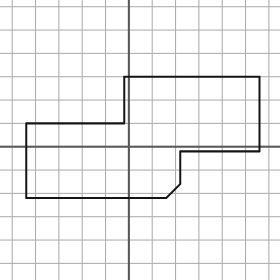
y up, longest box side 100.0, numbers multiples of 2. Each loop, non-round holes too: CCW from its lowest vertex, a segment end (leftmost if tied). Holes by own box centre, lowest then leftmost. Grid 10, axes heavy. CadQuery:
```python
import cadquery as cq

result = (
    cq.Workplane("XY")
    .moveTo(-44.0, -22.0)
    .lineTo(16.0, -22.0)
    .lineTo(22.0, -16.0)
    .lineTo(22.0, -2.0)
    .lineTo(56.0, -2.0)
    .lineTo(56.0, 30.0)
    .lineTo(-2.0, 30.0)
    .lineTo(-2.0, 10.0)
    .lineTo(-44.0, 10.0)
    .close()
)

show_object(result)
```